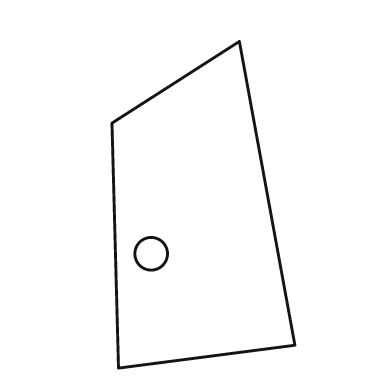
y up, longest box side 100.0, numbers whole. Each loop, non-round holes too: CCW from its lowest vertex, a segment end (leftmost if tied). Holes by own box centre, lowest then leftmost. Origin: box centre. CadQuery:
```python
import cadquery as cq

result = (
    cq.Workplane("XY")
    .moveTo(-26.0, -50.0)
    .lineTo(28.0, -43.0)
    .lineTo(11.0, 50.0)
    .lineTo(-28.0, 25.0)
    .close()
    .moveTo(-16.0, -15.0)
    .circle(5.0)
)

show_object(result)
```